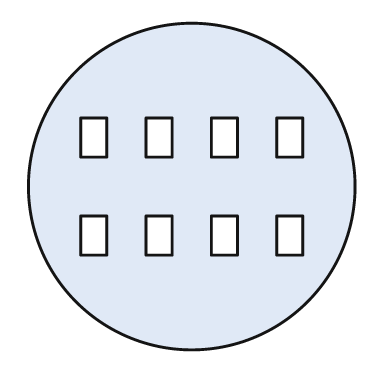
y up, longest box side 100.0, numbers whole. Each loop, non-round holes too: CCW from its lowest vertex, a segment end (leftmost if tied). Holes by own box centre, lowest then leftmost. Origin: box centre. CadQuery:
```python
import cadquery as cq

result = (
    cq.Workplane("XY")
    .moveTo(0.0, 0.0)
    .circle(50.0)
    .moveTo(-34.0, -21.0)
    .lineTo(-26.0, -21.0)
    .lineTo(-26.0, -9.0)
    .lineTo(-34.0, -9.0)
    .close()
    .moveTo(-14.0, -21.0)
    .lineTo(-6.0, -21.0)
    .lineTo(-6.0, -9.0)
    .lineTo(-14.0, -9.0)
    .close()
    .moveTo(6.0, -21.0)
    .lineTo(14.0, -21.0)
    .lineTo(14.0, -9.0)
    .lineTo(6.0, -9.0)
    .close()
    .moveTo(26.0, -21.0)
    .lineTo(34.0, -21.0)
    .lineTo(34.0, -9.0)
    .lineTo(26.0, -9.0)
    .close()
    .moveTo(-34.0, 9.0)
    .lineTo(-26.0, 9.0)
    .lineTo(-26.0, 21.0)
    .lineTo(-34.0, 21.0)
    .close()
    .moveTo(-14.0, 9.0)
    .lineTo(-6.0, 9.0)
    .lineTo(-6.0, 21.0)
    .lineTo(-14.0, 21.0)
    .close()
    .moveTo(6.0, 9.0)
    .lineTo(14.0, 9.0)
    .lineTo(14.0, 21.0)
    .lineTo(6.0, 21.0)
    .close()
    .moveTo(26.0, 9.0)
    .lineTo(34.0, 9.0)
    .lineTo(34.0, 21.0)
    .lineTo(26.0, 21.0)
    .close()
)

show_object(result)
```